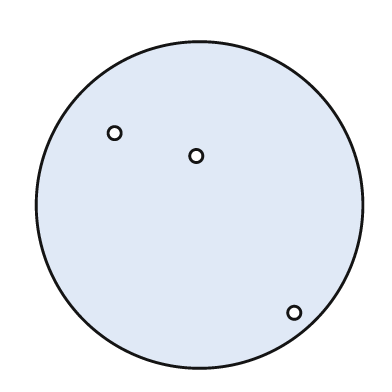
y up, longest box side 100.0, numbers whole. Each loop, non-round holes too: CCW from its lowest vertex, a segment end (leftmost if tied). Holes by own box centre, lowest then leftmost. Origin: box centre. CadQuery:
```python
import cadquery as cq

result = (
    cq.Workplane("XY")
    .moveTo(0.0, 0.0)
    .circle(50.0)
    .moveTo(29.0, -33.0)
    .circle(2.0)
    .moveTo(-1.0, 15.0)
    .circle(2.0)
    .moveTo(-26.0, 22.0)
    .circle(2.0)
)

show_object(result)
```